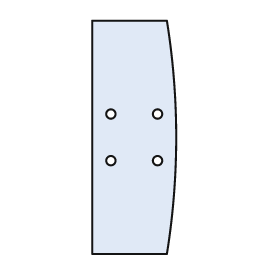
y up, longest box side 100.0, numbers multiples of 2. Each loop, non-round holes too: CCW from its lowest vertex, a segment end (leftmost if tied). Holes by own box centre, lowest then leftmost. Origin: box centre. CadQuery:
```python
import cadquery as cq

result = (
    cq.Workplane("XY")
    .moveTo(-18.0, -50.0)
    .lineTo(14.0, -50.0)
    .threePointArc((18.0, 0.0), (14.0, 50.0))
    .lineTo(-18.0, 50.0)
    .close()
    .moveTo(-10.0, -10.0)
    .circle(2.0)
    .moveTo(10.0, -10.0)
    .circle(2.0)
    .moveTo(-10.0, 10.0)
    .circle(2.0)
    .moveTo(10.0, 10.0)
    .circle(2.0)
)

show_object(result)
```